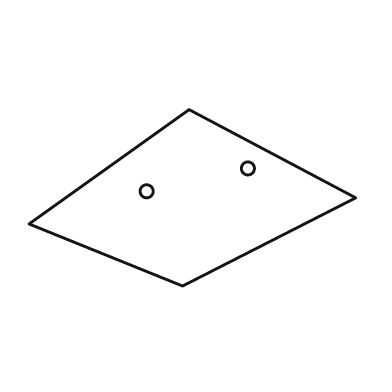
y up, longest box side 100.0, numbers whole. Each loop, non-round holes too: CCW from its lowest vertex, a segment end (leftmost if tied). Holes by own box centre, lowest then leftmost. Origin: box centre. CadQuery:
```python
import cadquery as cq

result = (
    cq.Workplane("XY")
    .moveTo(-3.0, -27.0)
    .lineTo(50.0, 0.0)
    .lineTo(-1.0, 27.0)
    .lineTo(-50.0, -8.0)
    .close()
    .moveTo(-14.0, 2.0)
    .circle(2.0)
    .moveTo(17.0, 9.0)
    .circle(2.0)
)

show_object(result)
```